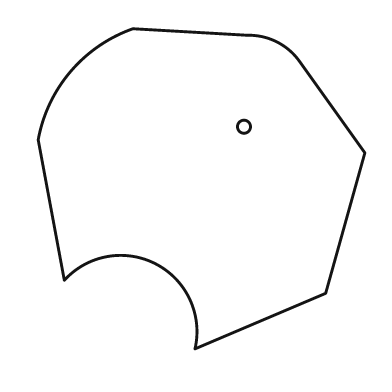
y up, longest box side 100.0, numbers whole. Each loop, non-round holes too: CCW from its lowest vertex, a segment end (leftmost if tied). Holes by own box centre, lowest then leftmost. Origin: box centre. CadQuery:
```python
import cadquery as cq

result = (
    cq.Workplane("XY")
    .moveTo(-2.0, -49.0)
    .lineTo(38.0, -32.0)
    .lineTo(50.0, 11.0)
    .lineTo(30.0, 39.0)
    .threePointArc((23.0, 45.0), (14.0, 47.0))
    .lineTo(-21.0, 49.0)
    .threePointArc((-40.0, 36.0), (-50.0, 15.0))
    .lineTo(-42.0, -28.0)
    .threePointArc((-14.0, -23.0), (-2.0, -49.0))
    .close()
    .moveTo(13.0, 19.0)
    .circle(2.0)
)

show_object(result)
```